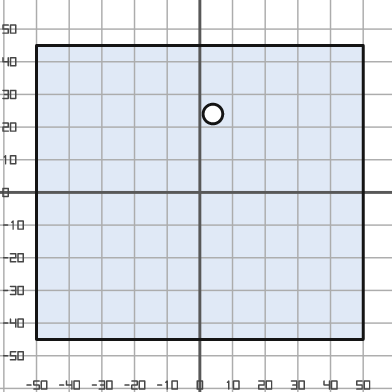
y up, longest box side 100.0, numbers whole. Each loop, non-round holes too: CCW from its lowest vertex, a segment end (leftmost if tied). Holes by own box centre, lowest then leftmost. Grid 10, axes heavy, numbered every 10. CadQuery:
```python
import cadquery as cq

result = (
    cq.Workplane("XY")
    .moveTo(-50.0, -45.0)
    .lineTo(50.0, -45.0)
    .lineTo(50.0, 45.0)
    .lineTo(-50.0, 45.0)
    .close()
    .moveTo(4.0, 24.0)
    .circle(3.0)
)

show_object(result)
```